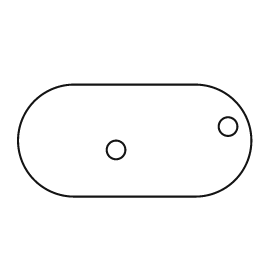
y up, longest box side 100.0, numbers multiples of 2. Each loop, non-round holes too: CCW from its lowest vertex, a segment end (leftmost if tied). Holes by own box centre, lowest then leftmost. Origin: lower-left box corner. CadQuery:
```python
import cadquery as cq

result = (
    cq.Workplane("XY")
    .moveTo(24.0, 0.0)
    .lineTo(76.0, 0.0)
    .threePointArc((100.0, 24.0), (76.0, 48.0))
    .lineTo(24.0, 48.0)
    .threePointArc((0.0, 24.0), (24.0, 0.0))
    .close()
    .moveTo(42.0, 20.0)
    .circle(4.0)
    .moveTo(90.0, 30.0)
    .circle(4.0)
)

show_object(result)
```